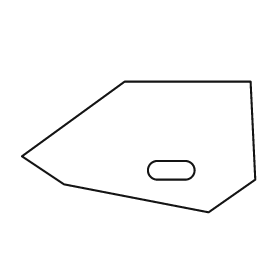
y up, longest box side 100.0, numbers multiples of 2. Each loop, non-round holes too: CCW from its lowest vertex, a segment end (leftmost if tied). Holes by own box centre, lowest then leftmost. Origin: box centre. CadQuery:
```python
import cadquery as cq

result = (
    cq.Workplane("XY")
    .moveTo(30.0, -28.0)
    .lineTo(50.0, -14.0)
    .lineTo(48.0, 28.0)
    .lineTo(-6.0, 28.0)
    .lineTo(-50.0, -4.0)
    .lineTo(-32.0, -16.0)
    .close()
    .moveTo(8.0, -14.0)
    .lineTo(20.0, -14.0)
    .threePointArc((24.0, -10.0), (20.0, -6.0))
    .lineTo(8.0, -6.0)
    .threePointArc((4.0, -10.0), (8.0, -14.0))
    .close()
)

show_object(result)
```